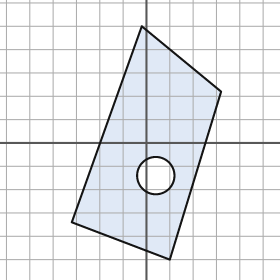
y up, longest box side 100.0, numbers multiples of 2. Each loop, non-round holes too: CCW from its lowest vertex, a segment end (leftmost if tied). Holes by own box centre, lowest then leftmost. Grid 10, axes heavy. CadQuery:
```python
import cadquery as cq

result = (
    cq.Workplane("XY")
    .moveTo(10.0, -50.0)
    .lineTo(32.0, 22.0)
    .lineTo(-2.0, 50.0)
    .lineTo(-32.0, -34.0)
    .close()
    .moveTo(4.0, -14.0)
    .circle(8.0)
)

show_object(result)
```